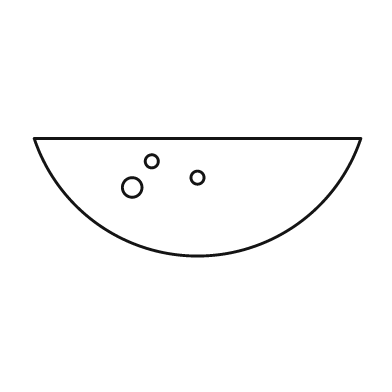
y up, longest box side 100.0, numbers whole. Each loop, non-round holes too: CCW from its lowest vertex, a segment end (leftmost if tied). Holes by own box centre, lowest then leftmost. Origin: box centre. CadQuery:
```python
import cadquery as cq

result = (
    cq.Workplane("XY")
    .moveTo(-50.0, 18.0)
    .threePointArc((0.0, -18.0), (50.0, 18.0))
    .close()
    .moveTo(-20.0, 3.0)
    .circle(3.0)
    .moveTo(0.0, 6.0)
    .circle(2.0)
    .moveTo(-14.0, 11.0)
    .circle(2.0)
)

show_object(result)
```